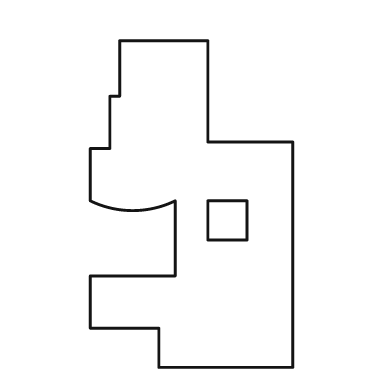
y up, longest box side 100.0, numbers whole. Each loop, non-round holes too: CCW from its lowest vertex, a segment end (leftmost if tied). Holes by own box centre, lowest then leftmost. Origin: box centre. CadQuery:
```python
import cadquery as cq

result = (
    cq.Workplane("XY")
    .moveTo(-10.0, -50.0)
    .lineTo(31.0, -50.0)
    .lineTo(31.0, 19.0)
    .lineTo(5.0, 19.0)
    .lineTo(5.0, 50.0)
    .lineTo(-22.0, 50.0)
    .lineTo(-22.0, 33.0)
    .lineTo(-25.0, 33.0)
    .lineTo(-25.0, 17.0)
    .lineTo(-31.0, 17.0)
    .lineTo(-31.0, 1.0)
    .threePointArc((-18.0, -2.0), (-5.0, 1.0))
    .lineTo(-5.0, -22.0)
    .lineTo(-31.0, -22.0)
    .lineTo(-31.0, -38.0)
    .lineTo(-10.0, -38.0)
    .close()
    .moveTo(5.0, -11.0)
    .lineTo(17.0, -11.0)
    .lineTo(17.0, 1.0)
    .lineTo(5.0, 1.0)
    .close()
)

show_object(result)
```